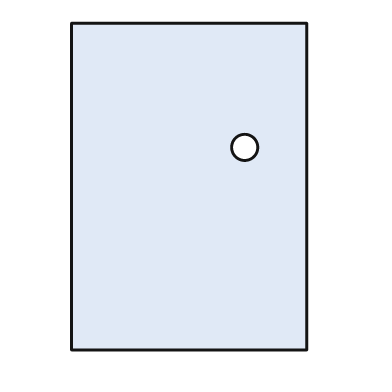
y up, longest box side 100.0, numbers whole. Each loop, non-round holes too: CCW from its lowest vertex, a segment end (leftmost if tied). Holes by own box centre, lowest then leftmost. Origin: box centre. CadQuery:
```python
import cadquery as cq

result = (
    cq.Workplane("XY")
    .moveTo(-36.0, -50.0)
    .lineTo(36.0, -50.0)
    .lineTo(36.0, 50.0)
    .lineTo(-36.0, 50.0)
    .close()
    .moveTo(17.0, 12.0)
    .circle(4.0)
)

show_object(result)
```